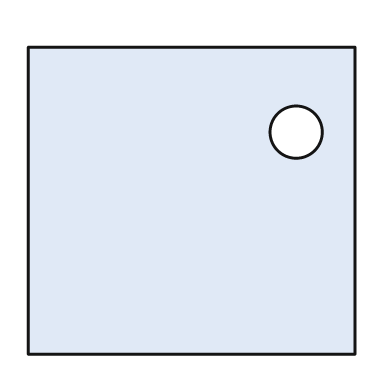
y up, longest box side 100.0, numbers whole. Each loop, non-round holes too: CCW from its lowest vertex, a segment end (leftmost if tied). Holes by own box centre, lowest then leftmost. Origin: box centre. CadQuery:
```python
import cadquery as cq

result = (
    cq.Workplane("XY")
    .moveTo(-50.0, -47.0)
    .lineTo(50.0, -47.0)
    .lineTo(50.0, 47.0)
    .lineTo(-50.0, 47.0)
    .close()
    .moveTo(32.0, 21.0)
    .circle(8.0)
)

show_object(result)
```